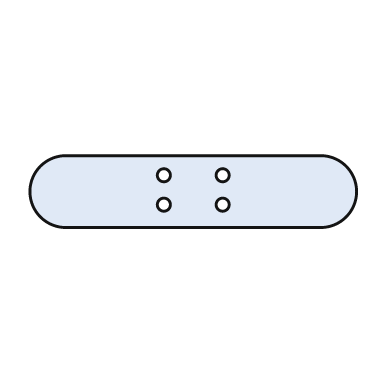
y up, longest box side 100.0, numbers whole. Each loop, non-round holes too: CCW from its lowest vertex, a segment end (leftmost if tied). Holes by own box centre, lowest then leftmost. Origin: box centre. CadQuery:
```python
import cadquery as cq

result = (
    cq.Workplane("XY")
    .moveTo(-39.0, -11.0)
    .lineTo(39.0, -11.0)
    .threePointArc((50.0, 0.0), (39.0, 11.0))
    .lineTo(-39.0, 11.0)
    .threePointArc((-50.0, 0.0), (-39.0, -11.0))
    .close()
    .moveTo(-9.0, -4.0)
    .circle(2.0)
    .moveTo(9.0, -4.0)
    .circle(2.0)
    .moveTo(-9.0, 5.0)
    .circle(2.0)
    .moveTo(9.0, 5.0)
    .circle(2.0)
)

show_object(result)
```